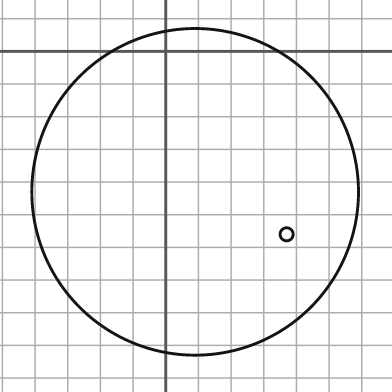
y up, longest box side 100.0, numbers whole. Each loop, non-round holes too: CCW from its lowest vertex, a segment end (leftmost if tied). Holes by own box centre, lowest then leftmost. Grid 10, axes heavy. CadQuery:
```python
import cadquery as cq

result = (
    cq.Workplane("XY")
    .moveTo(9.0, -43.0)
    .circle(50.0)
    .moveTo(37.0, -56.0)
    .circle(2.0)
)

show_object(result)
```